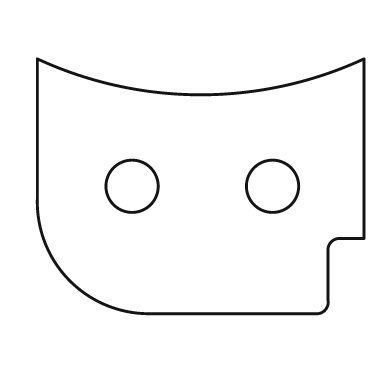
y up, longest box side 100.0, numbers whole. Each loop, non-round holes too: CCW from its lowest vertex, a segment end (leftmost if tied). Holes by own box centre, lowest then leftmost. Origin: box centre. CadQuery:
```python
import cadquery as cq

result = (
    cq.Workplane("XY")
    .moveTo(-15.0, -39.0)
    .lineTo(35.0, -39.0)
    .threePointArc((38.0, -38.0), (39.0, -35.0))
    .lineTo(39.0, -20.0)
    .threePointArc((40.0, -17.0), (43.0, -16.0))
    .lineTo(50.0, -16.0)
    .lineTo(50.0, 39.0)
    .threePointArc((0.0, 28.0), (-50.0, 39.0))
    .lineTo(-50.0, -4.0)
    .threePointArc((-40.0, -29.0), (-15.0, -39.0))
    .close()
    .moveTo(-21.0, 0.0)
    .circle(8.0)
    .moveTo(22.0, 0.0)
    .circle(8.0)
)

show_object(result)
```